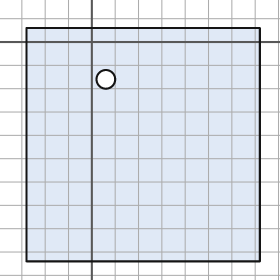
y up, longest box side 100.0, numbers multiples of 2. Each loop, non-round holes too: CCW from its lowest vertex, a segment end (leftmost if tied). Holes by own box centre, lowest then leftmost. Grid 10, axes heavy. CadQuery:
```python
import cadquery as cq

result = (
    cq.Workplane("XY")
    .moveTo(-28.0, -94.0)
    .lineTo(72.0, -94.0)
    .lineTo(72.0, 6.0)
    .lineTo(-28.0, 6.0)
    .close()
    .moveTo(6.0, -16.0)
    .circle(4.0)
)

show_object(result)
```